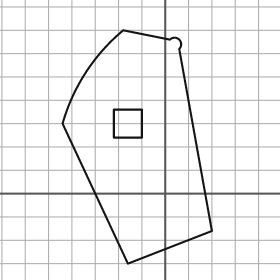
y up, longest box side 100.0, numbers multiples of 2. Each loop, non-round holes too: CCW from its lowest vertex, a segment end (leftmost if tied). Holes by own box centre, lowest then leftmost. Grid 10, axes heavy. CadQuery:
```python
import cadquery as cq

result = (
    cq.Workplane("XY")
    .moveTo(-16.0, -30.0)
    .lineTo(20.0, -16.0)
    .lineTo(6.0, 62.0)
    .threePointArc((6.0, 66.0), (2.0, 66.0))
    .lineTo(-18.0, 70.0)
    .threePointArc((-34.0, 52.0), (-44.0, 30.0))
    .close()
    .moveTo(-22.0, 24.0)
    .lineTo(-10.0, 24.0)
    .lineTo(-10.0, 36.0)
    .lineTo(-22.0, 36.0)
    .close()
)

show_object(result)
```